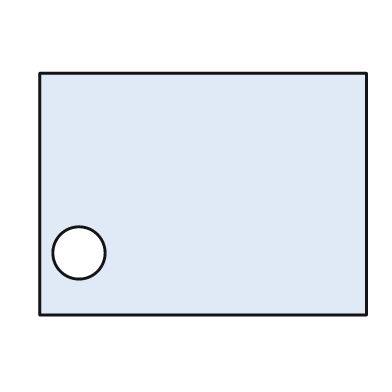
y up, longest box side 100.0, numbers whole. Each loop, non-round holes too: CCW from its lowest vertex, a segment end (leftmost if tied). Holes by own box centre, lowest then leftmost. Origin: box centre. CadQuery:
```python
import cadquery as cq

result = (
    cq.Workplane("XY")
    .moveTo(-50.0, -37.0)
    .lineTo(50.0, -37.0)
    .lineTo(50.0, 37.0)
    .lineTo(-50.0, 37.0)
    .close()
    .moveTo(-38.0, -18.0)
    .circle(8.0)
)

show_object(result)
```